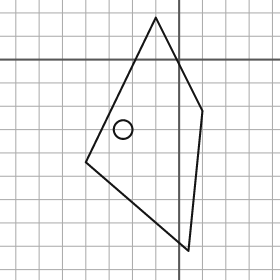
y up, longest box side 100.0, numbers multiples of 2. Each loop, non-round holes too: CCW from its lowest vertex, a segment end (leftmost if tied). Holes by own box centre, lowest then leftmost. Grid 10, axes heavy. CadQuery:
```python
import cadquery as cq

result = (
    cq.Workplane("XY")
    .moveTo(4.0, -82.0)
    .lineTo(10.0, -22.0)
    .lineTo(-10.0, 18.0)
    .lineTo(-40.0, -44.0)
    .close()
    .moveTo(-24.0, -30.0)
    .circle(4.0)
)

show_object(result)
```